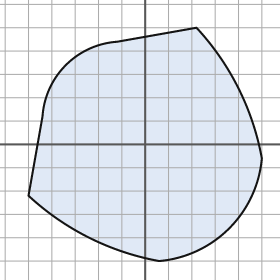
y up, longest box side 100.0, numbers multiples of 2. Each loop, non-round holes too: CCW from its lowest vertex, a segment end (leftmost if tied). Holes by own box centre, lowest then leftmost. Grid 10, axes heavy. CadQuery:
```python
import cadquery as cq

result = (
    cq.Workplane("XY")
    .moveTo(6.0, -50.0)
    .threePointArc((36.0, -36.0), (50.0, -6.0))
    .threePointArc((40.0, 24.0), (22.0, 50.0))
    .lineTo(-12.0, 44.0)
    .threePointArc((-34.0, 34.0), (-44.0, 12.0))
    .lineTo(-50.0, -22.0)
    .threePointArc((-24.0, -40.0), (6.0, -50.0))
    .close()
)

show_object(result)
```